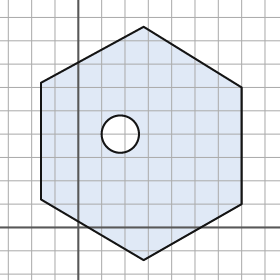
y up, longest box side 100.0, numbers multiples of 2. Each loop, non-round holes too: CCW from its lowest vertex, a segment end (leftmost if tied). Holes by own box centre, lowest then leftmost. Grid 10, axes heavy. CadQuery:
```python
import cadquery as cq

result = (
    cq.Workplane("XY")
    .moveTo(28.0, -14.0)
    .lineTo(70.0, 10.0)
    .lineTo(70.0, 60.0)
    .lineTo(28.0, 86.0)
    .lineTo(-16.0, 62.0)
    .lineTo(-16.0, 12.0)
    .close()
    .moveTo(18.0, 40.0)
    .circle(8.0)
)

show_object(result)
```